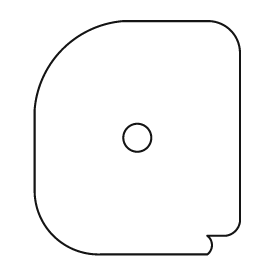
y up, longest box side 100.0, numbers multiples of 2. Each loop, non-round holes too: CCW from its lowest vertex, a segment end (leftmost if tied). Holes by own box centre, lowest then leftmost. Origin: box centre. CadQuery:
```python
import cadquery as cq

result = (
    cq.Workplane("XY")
    .moveTo(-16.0, -50.0)
    .lineTo(30.0, -50.0)
    .threePointArc((32.0, -46.0), (30.0, -42.0))
    .lineTo(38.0, -42.0)
    .threePointArc((42.0, -40.0), (44.0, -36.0))
    .lineTo(44.0, 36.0)
    .threePointArc((40.0, 46.0), (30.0, 50.0))
    .lineTo(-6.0, 50.0)
    .threePointArc((-32.0, 38.0), (-44.0, 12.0))
    .lineTo(-44.0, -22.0)
    .threePointArc((-36.0, -42.0), (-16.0, -50.0))
    .close()
    .moveTo(0.0, 0.0)
    .circle(6.0)
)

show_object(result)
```